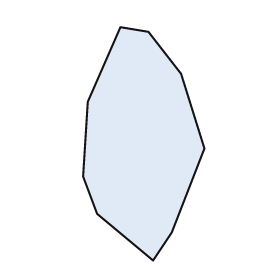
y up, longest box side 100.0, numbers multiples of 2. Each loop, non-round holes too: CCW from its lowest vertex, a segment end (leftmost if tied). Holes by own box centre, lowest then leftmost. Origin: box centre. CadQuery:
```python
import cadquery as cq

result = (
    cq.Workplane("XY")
    .moveTo(4.0, -50.0)
    .lineTo(12.0, -38.0)
    .lineTo(26.0, -2.0)
    .lineTo(16.0, 30.0)
    .lineTo(2.0, 48.0)
    .lineTo(-10.0, 50.0)
    .lineTo(-24.0, 18.0)
    .lineTo(-26.0, -14.0)
    .lineTo(-20.0, -30.0)
    .close()
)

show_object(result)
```